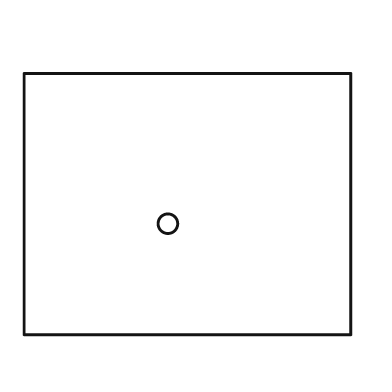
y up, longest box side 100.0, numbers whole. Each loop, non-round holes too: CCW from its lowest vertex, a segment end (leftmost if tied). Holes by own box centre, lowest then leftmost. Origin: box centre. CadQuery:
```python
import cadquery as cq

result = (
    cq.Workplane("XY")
    .moveTo(-50.0, -40.0)
    .lineTo(50.0, -40.0)
    .lineTo(50.0, 40.0)
    .lineTo(-50.0, 40.0)
    .close()
    .moveTo(-6.0, -6.0)
    .circle(3.0)
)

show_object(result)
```